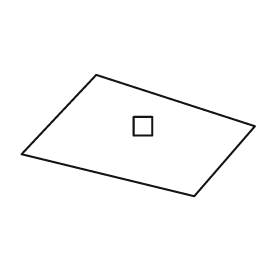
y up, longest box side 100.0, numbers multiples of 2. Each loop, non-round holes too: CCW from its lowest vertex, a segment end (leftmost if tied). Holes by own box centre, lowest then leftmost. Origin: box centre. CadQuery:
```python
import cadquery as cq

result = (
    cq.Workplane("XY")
    .moveTo(24.0, -26.0)
    .lineTo(50.0, 4.0)
    .lineTo(-18.0, 26.0)
    .lineTo(-50.0, -8.0)
    .close()
    .moveTo(-2.0, 0.0)
    .lineTo(6.0, 0.0)
    .lineTo(6.0, 8.0)
    .lineTo(-2.0, 8.0)
    .close()
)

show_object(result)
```